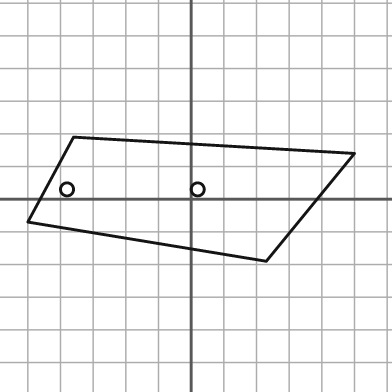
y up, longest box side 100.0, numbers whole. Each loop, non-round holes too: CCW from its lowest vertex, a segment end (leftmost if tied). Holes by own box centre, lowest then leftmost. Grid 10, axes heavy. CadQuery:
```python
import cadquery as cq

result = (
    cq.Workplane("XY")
    .moveTo(23.0, -19.0)
    .lineTo(50.0, 14.0)
    .lineTo(-36.0, 19.0)
    .lineTo(-50.0, -7.0)
    .close()
    .moveTo(-38.0, 3.0)
    .circle(2.0)
    .moveTo(2.0, 3.0)
    .circle(2.0)
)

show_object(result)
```